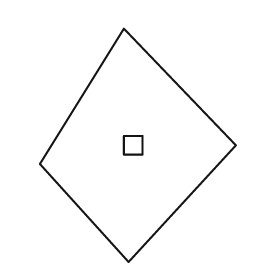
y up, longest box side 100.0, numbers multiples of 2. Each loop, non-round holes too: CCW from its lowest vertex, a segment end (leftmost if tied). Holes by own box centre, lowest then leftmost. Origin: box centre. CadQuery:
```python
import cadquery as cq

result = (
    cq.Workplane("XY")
    .moveTo(-4.0, -50.0)
    .lineTo(42.0, 0.0)
    .lineTo(-6.0, 50.0)
    .lineTo(-42.0, -8.0)
    .close()
    .moveTo(-6.0, -4.0)
    .lineTo(2.0, -4.0)
    .lineTo(2.0, 4.0)
    .lineTo(-6.0, 4.0)
    .close()
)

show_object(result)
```